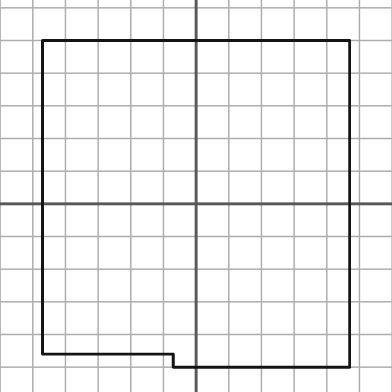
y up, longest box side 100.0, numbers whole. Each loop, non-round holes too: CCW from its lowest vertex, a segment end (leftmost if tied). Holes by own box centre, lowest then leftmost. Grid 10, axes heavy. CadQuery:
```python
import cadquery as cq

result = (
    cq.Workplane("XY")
    .moveTo(-7.0, -50.0)
    .lineTo(47.0, -50.0)
    .lineTo(47.0, 50.0)
    .lineTo(-47.0, 50.0)
    .lineTo(-47.0, -46.0)
    .lineTo(-7.0, -46.0)
    .close()
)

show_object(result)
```